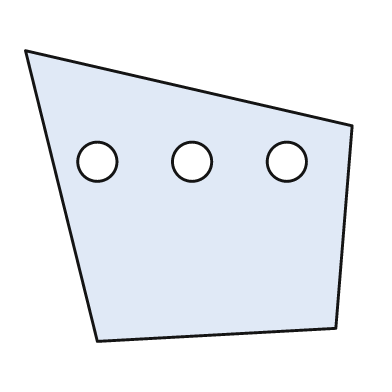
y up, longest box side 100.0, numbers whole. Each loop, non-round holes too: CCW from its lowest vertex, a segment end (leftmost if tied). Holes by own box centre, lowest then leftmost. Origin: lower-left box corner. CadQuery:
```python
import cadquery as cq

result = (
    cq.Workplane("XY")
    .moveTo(22.0, 0.0)
    .lineTo(95.0, 4.0)
    .lineTo(100.0, 66.0)
    .lineTo(0.0, 89.0)
    .close()
    .moveTo(22.0, 55.0)
    .circle(6.0)
    .moveTo(51.0, 55.0)
    .circle(6.0)
    .moveTo(80.0, 55.0)
    .circle(6.0)
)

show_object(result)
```